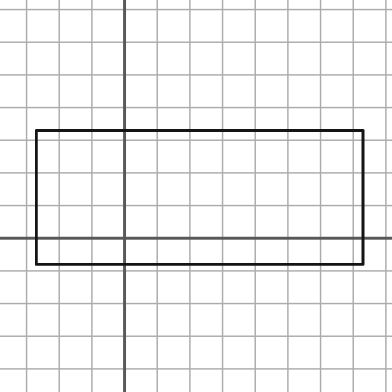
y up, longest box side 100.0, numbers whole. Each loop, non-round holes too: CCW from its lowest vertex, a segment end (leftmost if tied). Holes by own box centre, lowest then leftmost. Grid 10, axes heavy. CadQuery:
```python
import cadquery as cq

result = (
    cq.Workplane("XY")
    .moveTo(-27.0, -8.0)
    .lineTo(73.0, -8.0)
    .lineTo(73.0, 33.0)
    .lineTo(-27.0, 33.0)
    .close()
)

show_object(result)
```